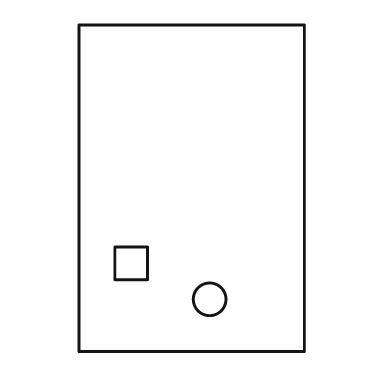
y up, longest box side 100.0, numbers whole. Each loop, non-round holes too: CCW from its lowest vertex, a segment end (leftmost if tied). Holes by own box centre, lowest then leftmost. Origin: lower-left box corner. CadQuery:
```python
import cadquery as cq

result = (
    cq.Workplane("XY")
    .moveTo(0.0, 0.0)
    .lineTo(69.0, 0.0)
    .lineTo(69.0, 100.0)
    .lineTo(0.0, 100.0)
    .close()
    .moveTo(40.0, 16.0)
    .circle(5.0)
    .moveTo(11.0, 22.0)
    .lineTo(21.0, 22.0)
    .lineTo(21.0, 32.0)
    .lineTo(11.0, 32.0)
    .close()
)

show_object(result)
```